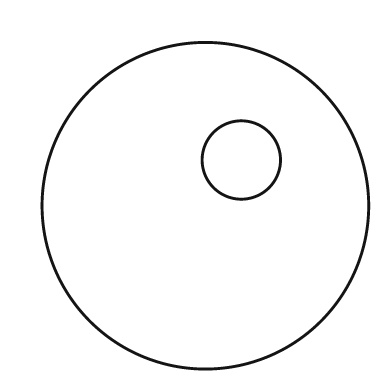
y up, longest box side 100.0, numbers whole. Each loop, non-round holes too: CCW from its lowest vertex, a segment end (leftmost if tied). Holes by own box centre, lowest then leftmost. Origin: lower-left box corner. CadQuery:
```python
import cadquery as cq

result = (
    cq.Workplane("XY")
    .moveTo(50.0, 50.0)
    .circle(50.0)
    .moveTo(61.0, 64.0)
    .circle(12.0)
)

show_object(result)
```